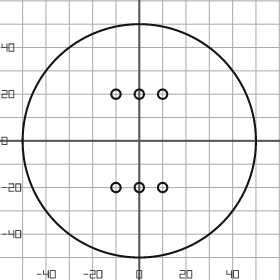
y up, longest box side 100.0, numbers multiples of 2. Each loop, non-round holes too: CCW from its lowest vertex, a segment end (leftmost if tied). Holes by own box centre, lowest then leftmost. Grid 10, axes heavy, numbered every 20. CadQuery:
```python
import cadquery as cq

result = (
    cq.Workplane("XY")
    .moveTo(0.0, 0.0)
    .circle(50.0)
    .moveTo(-10.0, -20.0)
    .circle(2.0)
    .moveTo(0.0, -20.0)
    .circle(2.0)
    .moveTo(10.0, -20.0)
    .circle(2.0)
    .moveTo(-10.0, 20.0)
    .circle(2.0)
    .moveTo(0.0, 20.0)
    .circle(2.0)
    .moveTo(10.0, 20.0)
    .circle(2.0)
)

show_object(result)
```